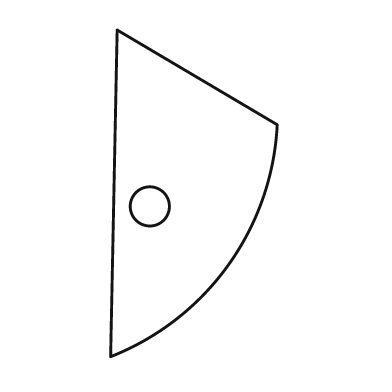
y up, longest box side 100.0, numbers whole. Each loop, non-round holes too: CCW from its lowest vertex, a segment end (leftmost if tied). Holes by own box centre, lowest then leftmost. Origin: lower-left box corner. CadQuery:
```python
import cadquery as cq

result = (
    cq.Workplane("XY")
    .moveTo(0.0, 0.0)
    .threePointArc((36.0, 28.0), (51.0, 71.0))
    .lineTo(2.0, 100.0)
    .close()
    .moveTo(12.0, 46.0)
    .circle(6.0)
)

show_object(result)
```